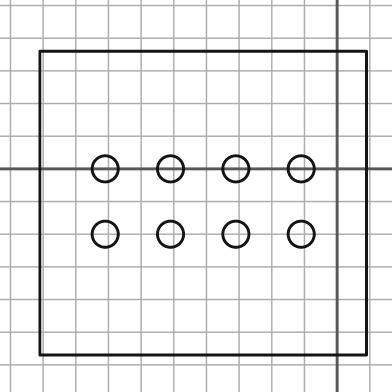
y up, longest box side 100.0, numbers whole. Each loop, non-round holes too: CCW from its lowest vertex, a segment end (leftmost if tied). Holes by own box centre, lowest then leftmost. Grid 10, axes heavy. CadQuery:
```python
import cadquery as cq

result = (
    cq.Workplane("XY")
    .moveTo(-91.0, -57.0)
    .lineTo(9.0, -57.0)
    .lineTo(9.0, 36.0)
    .lineTo(-91.0, 36.0)
    .close()
    .moveTo(-71.0, -20.0)
    .circle(4.0)
    .moveTo(-51.0, -20.0)
    .circle(4.0)
    .moveTo(-31.0, -20.0)
    .circle(4.0)
    .moveTo(-11.0, -20.0)
    .circle(4.0)
    .moveTo(-71.0, 0.0)
    .circle(4.0)
    .moveTo(-51.0, 0.0)
    .circle(4.0)
    .moveTo(-31.0, 0.0)
    .circle(4.0)
    .moveTo(-11.0, 0.0)
    .circle(4.0)
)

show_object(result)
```